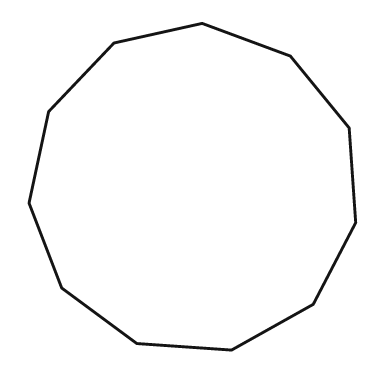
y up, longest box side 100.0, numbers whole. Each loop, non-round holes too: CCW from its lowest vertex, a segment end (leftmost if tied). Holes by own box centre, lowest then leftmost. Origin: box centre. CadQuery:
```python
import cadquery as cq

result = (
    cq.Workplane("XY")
    .moveTo(12.0, -50.0)
    .lineTo(37.0, -36.0)
    .lineTo(50.0, -11.0)
    .lineTo(48.0, 18.0)
    .lineTo(30.0, 40.0)
    .lineTo(3.0, 50.0)
    .lineTo(-24.0, 44.0)
    .lineTo(-44.0, 23.0)
    .lineTo(-50.0, -5.0)
    .lineTo(-40.0, -31.0)
    .lineTo(-17.0, -48.0)
    .close()
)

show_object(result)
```